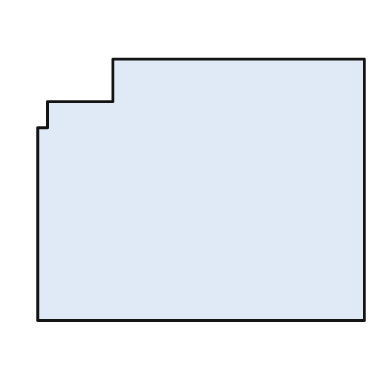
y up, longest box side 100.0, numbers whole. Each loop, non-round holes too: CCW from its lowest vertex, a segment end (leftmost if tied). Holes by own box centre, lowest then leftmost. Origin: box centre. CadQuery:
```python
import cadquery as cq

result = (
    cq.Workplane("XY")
    .moveTo(-50.0, -40.0)
    .lineTo(50.0, -40.0)
    .lineTo(50.0, 40.0)
    .lineTo(-27.0, 40.0)
    .lineTo(-27.0, 27.0)
    .lineTo(-47.0, 27.0)
    .lineTo(-47.0, 19.0)
    .lineTo(-50.0, 19.0)
    .close()
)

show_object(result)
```